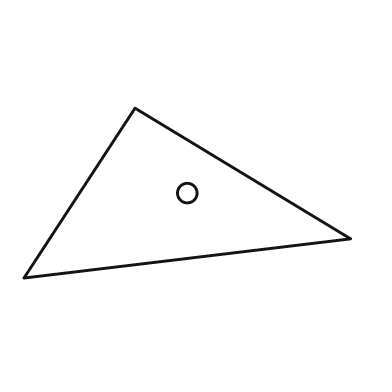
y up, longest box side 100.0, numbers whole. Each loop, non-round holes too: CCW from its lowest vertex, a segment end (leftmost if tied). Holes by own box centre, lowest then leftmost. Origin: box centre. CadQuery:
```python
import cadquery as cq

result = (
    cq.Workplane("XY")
    .moveTo(-50.0, -26.0)
    .lineTo(50.0, -14.0)
    .lineTo(-16.0, 26.0)
    .close()
    .moveTo(0.0, 0.0)
    .circle(3.0)
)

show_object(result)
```